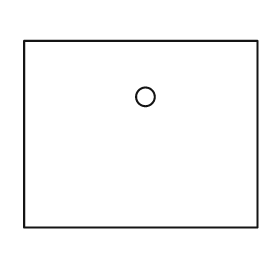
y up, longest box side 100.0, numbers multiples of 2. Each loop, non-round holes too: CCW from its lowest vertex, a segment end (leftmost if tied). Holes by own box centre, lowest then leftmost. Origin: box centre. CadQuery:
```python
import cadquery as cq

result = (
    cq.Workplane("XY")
    .moveTo(-50.0, -40.0)
    .lineTo(50.0, -40.0)
    .lineTo(50.0, 40.0)
    .lineTo(-50.0, 40.0)
    .close()
    .moveTo(2.0, 16.0)
    .circle(4.0)
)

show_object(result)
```